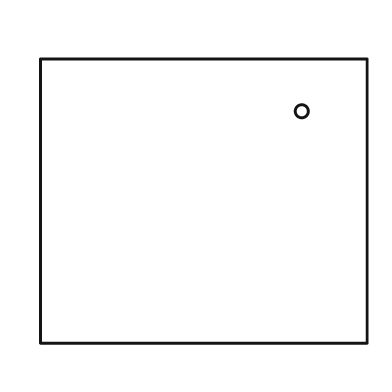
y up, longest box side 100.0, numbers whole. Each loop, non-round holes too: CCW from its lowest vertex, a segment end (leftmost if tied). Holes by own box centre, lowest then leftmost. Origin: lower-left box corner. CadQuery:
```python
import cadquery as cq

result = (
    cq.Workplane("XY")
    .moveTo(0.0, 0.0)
    .lineTo(100.0, 0.0)
    .lineTo(100.0, 87.0)
    .lineTo(0.0, 87.0)
    .close()
    .moveTo(80.0, 71.0)
    .circle(2.0)
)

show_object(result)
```